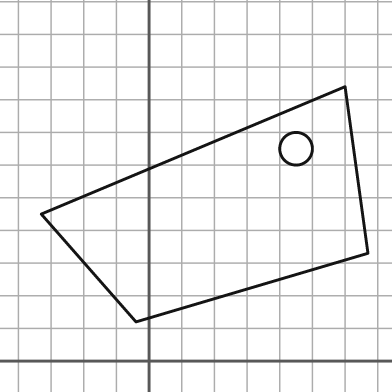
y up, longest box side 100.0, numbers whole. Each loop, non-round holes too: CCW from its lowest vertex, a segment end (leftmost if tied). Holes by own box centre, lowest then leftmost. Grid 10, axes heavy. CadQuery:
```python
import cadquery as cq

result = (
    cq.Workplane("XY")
    .moveTo(-4.0, 12.0)
    .lineTo(67.0, 33.0)
    .lineTo(60.0, 84.0)
    .lineTo(-33.0, 45.0)
    .close()
    .moveTo(45.0, 65.0)
    .circle(5.0)
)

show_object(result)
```